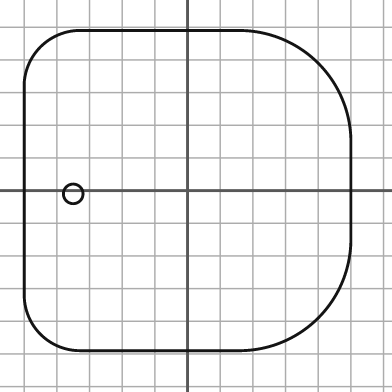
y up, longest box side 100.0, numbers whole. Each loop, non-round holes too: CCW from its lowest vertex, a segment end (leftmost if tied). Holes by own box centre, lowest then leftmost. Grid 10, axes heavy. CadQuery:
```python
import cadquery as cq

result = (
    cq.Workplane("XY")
    .moveTo(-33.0, -49.0)
    .lineTo(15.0, -49.0)
    .threePointArc((40.0, -39.0), (50.0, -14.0))
    .lineTo(50.0, 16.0)
    .threePointArc((40.0, 39.0), (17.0, 49.0))
    .lineTo(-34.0, 49.0)
    .threePointArc((-45.0, 44.0), (-50.0, 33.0))
    .lineTo(-50.0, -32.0)
    .threePointArc((-45.0, -44.0), (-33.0, -49.0))
    .close()
    .moveTo(-35.0, -1.0)
    .circle(3.0)
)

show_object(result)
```